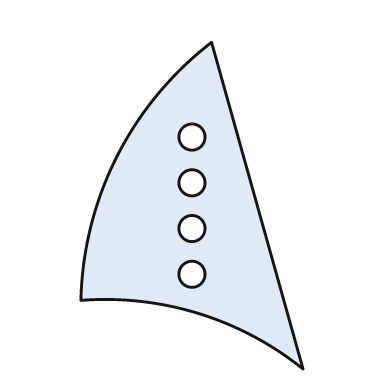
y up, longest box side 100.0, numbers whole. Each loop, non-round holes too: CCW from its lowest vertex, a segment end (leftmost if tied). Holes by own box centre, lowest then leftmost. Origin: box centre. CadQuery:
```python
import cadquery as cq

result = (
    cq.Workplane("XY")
    .moveTo(34.0, -50.0)
    .lineTo(6.0, 50.0)
    .threePointArc((-23.0, 15.0), (-34.0, -29.0))
    .threePointArc((2.0, -33.0), (34.0, -50.0))
    .close()
    .moveTo(0.0, -21.0)
    .circle(4.0)
    .moveTo(0.0, -7.0)
    .circle(4.0)
    .moveTo(0.0, 7.0)
    .circle(4.0)
    .moveTo(0.0, 21.0)
    .circle(4.0)
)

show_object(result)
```